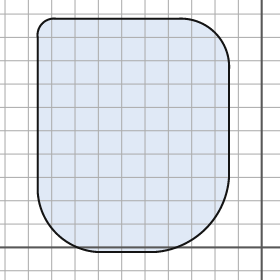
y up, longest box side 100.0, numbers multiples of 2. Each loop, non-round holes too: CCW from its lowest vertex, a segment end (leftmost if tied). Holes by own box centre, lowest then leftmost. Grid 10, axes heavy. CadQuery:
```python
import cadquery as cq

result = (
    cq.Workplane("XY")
    .moveTo(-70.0, -2.0)
    .lineTo(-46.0, -2.0)
    .threePointArc((-24.0, 8.0), (-14.0, 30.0))
    .lineTo(-14.0, 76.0)
    .threePointArc((-20.0, 92.0), (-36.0, 98.0))
    .lineTo(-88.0, 98.0)
    .threePointArc((-94.0, 96.0), (-96.0, 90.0))
    .lineTo(-96.0, 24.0)
    .threePointArc((-88.0, 6.0), (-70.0, -2.0))
    .close()
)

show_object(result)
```